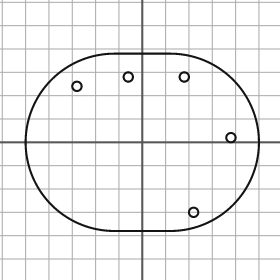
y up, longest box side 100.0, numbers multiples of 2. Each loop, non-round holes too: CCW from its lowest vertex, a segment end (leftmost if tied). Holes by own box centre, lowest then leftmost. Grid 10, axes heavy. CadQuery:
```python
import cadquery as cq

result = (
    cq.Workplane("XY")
    .moveTo(-12.0, -38.0)
    .lineTo(12.0, -38.0)
    .threePointArc((50.0, 0.0), (12.0, 38.0))
    .lineTo(-12.0, 38.0)
    .threePointArc((-50.0, 0.0), (-12.0, -38.0))
    .close()
    .moveTo(22.0, -30.0)
    .circle(2.0)
    .moveTo(38.0, 2.0)
    .circle(2.0)
    .moveTo(-28.0, 24.0)
    .circle(2.0)
    .moveTo(-6.0, 28.0)
    .circle(2.0)
    .moveTo(18.0, 28.0)
    .circle(2.0)
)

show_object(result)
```